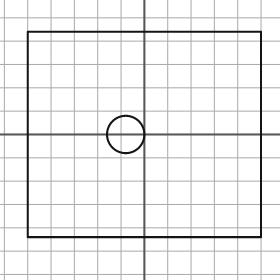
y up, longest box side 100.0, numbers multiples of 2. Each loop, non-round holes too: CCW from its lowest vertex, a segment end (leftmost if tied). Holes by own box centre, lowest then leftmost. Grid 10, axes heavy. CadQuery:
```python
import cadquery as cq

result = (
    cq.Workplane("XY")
    .moveTo(-50.0, -44.0)
    .lineTo(50.0, -44.0)
    .lineTo(50.0, 44.0)
    .lineTo(-50.0, 44.0)
    .close()
    .moveTo(-8.0, 0.0)
    .circle(8.0)
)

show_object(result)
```